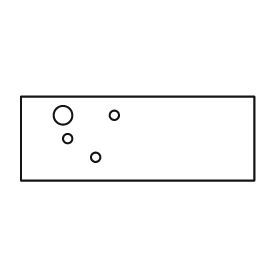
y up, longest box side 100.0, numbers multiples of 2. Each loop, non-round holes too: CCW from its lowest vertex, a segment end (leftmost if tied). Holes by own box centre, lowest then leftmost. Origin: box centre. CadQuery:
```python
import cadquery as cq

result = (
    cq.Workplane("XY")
    .moveTo(-50.0, -18.0)
    .lineTo(50.0, -18.0)
    .lineTo(50.0, 18.0)
    .lineTo(-50.0, 18.0)
    .close()
    .moveTo(-18.0, -8.0)
    .circle(2.0)
    .moveTo(-30.0, 0.0)
    .circle(2.0)
    .moveTo(-32.0, 10.0)
    .circle(4.0)
    .moveTo(-10.0, 10.0)
    .circle(2.0)
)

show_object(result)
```